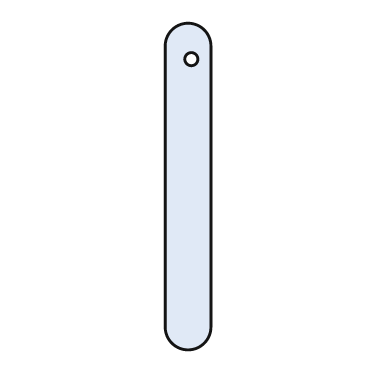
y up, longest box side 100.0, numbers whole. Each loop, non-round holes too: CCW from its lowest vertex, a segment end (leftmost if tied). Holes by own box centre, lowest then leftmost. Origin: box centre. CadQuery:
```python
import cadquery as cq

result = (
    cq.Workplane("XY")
    .moveTo(-7.0, -43.0)
    .threePointArc((0.0, -50.0), (7.0, -43.0))
    .lineTo(7.0, 43.0)
    .threePointArc((0.0, 50.0), (-7.0, 43.0))
    .close()
    .moveTo(1.0, 39.0)
    .circle(2.0)
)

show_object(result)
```